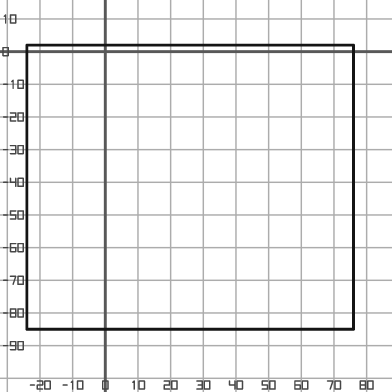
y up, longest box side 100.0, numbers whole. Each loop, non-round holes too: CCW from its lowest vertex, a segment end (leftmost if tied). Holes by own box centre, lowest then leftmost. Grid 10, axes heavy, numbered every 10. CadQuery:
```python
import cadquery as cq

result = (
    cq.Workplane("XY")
    .moveTo(-24.0, -85.0)
    .lineTo(76.0, -85.0)
    .lineTo(76.0, 2.0)
    .lineTo(-24.0, 2.0)
    .close()
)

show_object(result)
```